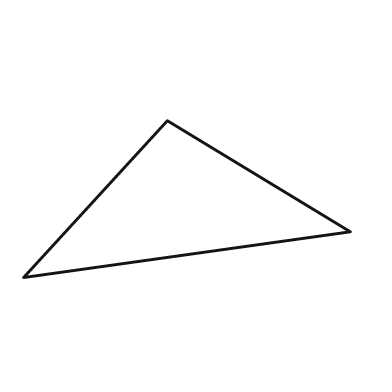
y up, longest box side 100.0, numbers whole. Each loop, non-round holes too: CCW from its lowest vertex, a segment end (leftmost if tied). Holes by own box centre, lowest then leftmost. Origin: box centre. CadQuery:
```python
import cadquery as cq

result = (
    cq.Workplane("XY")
    .moveTo(-50.0, -24.0)
    .lineTo(50.0, -10.0)
    .lineTo(-6.0, 24.0)
    .close()
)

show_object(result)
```